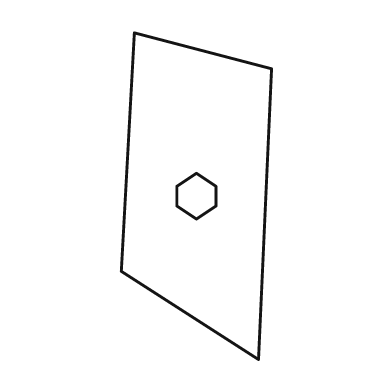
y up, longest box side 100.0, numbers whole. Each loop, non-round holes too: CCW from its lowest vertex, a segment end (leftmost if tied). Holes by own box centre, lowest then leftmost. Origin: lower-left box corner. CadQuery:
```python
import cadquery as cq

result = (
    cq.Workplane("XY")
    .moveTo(42.0, 0.0)
    .lineTo(46.0, 89.0)
    .lineTo(4.0, 100.0)
    .lineTo(0.0, 27.0)
    .close()
    .moveTo(23.0, 43.0)
    .lineTo(29.0, 47.0)
    .lineTo(29.0, 53.0)
    .lineTo(23.0, 57.0)
    .lineTo(17.0, 53.0)
    .lineTo(17.0, 47.0)
    .close()
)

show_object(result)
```